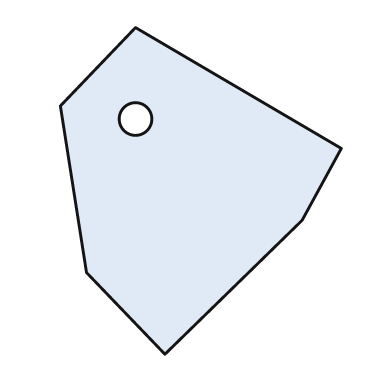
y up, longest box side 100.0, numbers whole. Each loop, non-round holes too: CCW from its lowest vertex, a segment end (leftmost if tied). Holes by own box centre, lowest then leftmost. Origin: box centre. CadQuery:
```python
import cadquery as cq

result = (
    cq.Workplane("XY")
    .moveTo(-11.0, -50.0)
    .lineTo(31.0, -9.0)
    .lineTo(43.0, 13.0)
    .lineTo(-20.0, 50.0)
    .lineTo(-43.0, 26.0)
    .lineTo(-35.0, -25.0)
    .close()
    .moveTo(-20.0, 22.0)
    .circle(5.0)
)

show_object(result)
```